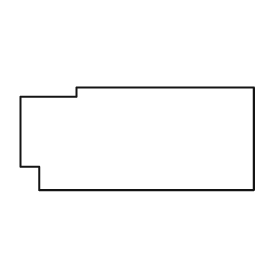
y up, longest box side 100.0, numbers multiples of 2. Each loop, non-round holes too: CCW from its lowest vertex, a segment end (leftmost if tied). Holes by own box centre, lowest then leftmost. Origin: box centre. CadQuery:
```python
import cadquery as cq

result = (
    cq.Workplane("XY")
    .moveTo(-42.0, -22.0)
    .lineTo(50.0, -22.0)
    .lineTo(50.0, 22.0)
    .lineTo(-26.0, 22.0)
    .lineTo(-26.0, 18.0)
    .lineTo(-50.0, 18.0)
    .lineTo(-50.0, -12.0)
    .lineTo(-42.0, -12.0)
    .close()
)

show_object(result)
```